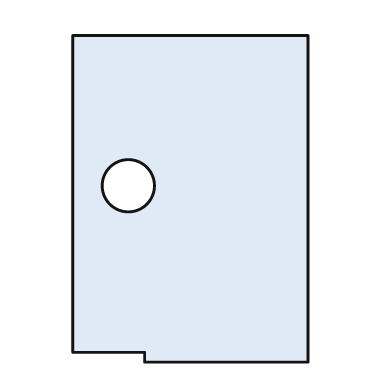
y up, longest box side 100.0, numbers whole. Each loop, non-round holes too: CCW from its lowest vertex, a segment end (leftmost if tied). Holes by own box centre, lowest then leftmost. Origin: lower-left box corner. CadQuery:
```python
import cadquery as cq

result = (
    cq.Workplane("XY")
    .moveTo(22.0, 0.0)
    .lineTo(72.0, 0.0)
    .lineTo(72.0, 100.0)
    .lineTo(0.0, 100.0)
    .lineTo(0.0, 3.0)
    .lineTo(22.0, 3.0)
    .close()
    .moveTo(17.0, 54.0)
    .circle(8.0)
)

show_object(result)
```